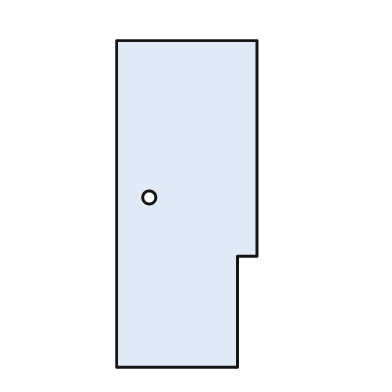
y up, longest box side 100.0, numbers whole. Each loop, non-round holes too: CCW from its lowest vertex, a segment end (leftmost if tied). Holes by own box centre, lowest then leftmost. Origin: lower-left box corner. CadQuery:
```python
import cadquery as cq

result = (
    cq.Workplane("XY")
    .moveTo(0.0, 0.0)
    .lineTo(37.0, 0.0)
    .lineTo(37.0, 34.0)
    .lineTo(43.0, 34.0)
    .lineTo(43.0, 100.0)
    .lineTo(0.0, 100.0)
    .close()
    .moveTo(10.0, 52.0)
    .circle(2.0)
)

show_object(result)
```